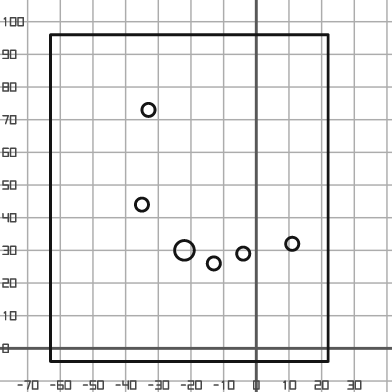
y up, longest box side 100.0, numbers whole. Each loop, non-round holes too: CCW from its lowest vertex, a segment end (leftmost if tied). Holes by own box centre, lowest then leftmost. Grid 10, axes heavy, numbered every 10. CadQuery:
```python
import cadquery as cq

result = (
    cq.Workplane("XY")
    .moveTo(-63.0, -4.0)
    .lineTo(22.0, -4.0)
    .lineTo(22.0, 96.0)
    .lineTo(-63.0, 96.0)
    .close()
    .moveTo(-13.0, 26.0)
    .circle(2.0)
    .moveTo(-4.0, 29.0)
    .circle(2.0)
    .moveTo(-22.0, 30.0)
    .circle(3.0)
    .moveTo(11.0, 32.0)
    .circle(2.0)
    .moveTo(-35.0, 44.0)
    .circle(2.0)
    .moveTo(-33.0, 73.0)
    .circle(2.0)
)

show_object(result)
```